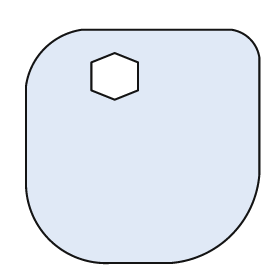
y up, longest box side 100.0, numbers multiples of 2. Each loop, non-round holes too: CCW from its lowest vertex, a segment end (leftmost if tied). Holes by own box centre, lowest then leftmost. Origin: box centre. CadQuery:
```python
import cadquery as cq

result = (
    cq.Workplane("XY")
    .moveTo(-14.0, -50.0)
    .lineTo(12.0, -50.0)
    .threePointArc((38.0, -38.0), (50.0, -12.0))
    .lineTo(50.0, 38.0)
    .threePointArc((46.0, 46.0), (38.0, 50.0))
    .lineTo(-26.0, 50.0)
    .threePointArc((-42.0, 42.0), (-50.0, 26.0))
    .lineTo(-50.0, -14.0)
    .threePointArc((-40.0, -40.0), (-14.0, -50.0))
    .close()
    .moveTo(-12.0, 20.0)
    .lineTo(-2.0, 24.0)
    .lineTo(-2.0, 36.0)
    .lineTo(-12.0, 40.0)
    .lineTo(-22.0, 36.0)
    .lineTo(-22.0, 24.0)
    .close()
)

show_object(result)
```